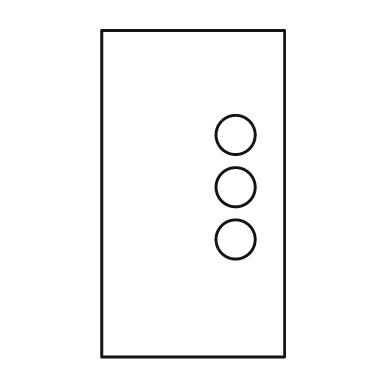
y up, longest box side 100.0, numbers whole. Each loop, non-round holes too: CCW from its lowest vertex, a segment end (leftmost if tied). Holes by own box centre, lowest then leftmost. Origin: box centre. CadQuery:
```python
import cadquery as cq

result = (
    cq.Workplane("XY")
    .moveTo(-28.0, -50.0)
    .lineTo(28.0, -50.0)
    .lineTo(28.0, 50.0)
    .lineTo(-28.0, 50.0)
    .close()
    .moveTo(13.0, -14.0)
    .circle(6.0)
    .moveTo(13.0, 2.0)
    .circle(6.0)
    .moveTo(13.0, 18.0)
    .circle(6.0)
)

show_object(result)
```